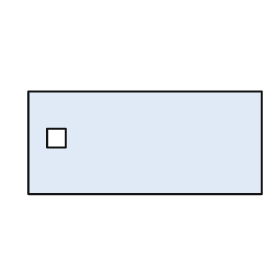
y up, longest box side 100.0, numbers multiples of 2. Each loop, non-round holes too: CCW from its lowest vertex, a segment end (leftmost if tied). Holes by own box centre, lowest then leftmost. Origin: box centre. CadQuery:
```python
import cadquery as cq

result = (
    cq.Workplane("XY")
    .moveTo(-50.0, -22.0)
    .lineTo(50.0, -22.0)
    .lineTo(50.0, 22.0)
    .lineTo(-50.0, 22.0)
    .close()
    .moveTo(-42.0, -2.0)
    .lineTo(-34.0, -2.0)
    .lineTo(-34.0, 6.0)
    .lineTo(-42.0, 6.0)
    .close()
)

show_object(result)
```